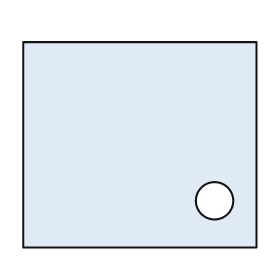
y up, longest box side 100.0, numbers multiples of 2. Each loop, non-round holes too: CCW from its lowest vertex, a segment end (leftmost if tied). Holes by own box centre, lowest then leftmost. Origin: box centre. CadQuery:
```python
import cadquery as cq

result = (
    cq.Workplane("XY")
    .moveTo(-50.0, -44.0)
    .lineTo(50.0, -44.0)
    .lineTo(50.0, 44.0)
    .lineTo(-50.0, 44.0)
    .close()
    .moveTo(32.0, -24.0)
    .circle(8.0)
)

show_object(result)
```